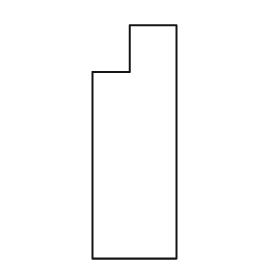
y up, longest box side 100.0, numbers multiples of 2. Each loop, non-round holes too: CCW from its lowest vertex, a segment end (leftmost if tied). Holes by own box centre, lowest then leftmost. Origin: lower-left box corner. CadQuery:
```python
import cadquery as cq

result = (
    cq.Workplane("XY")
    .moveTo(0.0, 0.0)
    .lineTo(36.0, 0.0)
    .lineTo(36.0, 100.0)
    .lineTo(16.0, 100.0)
    .lineTo(16.0, 80.0)
    .lineTo(0.0, 80.0)
    .close()
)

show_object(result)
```